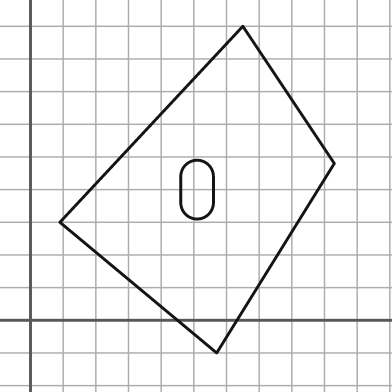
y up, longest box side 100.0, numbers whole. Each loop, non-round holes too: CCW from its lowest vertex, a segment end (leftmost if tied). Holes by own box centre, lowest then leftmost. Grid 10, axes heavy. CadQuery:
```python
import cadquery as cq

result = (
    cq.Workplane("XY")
    .moveTo(57.0, -10.0)
    .lineTo(93.0, 48.0)
    .lineTo(65.0, 90.0)
    .lineTo(9.0, 30.0)
    .close()
    .moveTo(46.0, 36.0)
    .threePointArc((51.0, 31.0), (56.0, 36.0))
    .lineTo(56.0, 44.0)
    .threePointArc((51.0, 49.0), (46.0, 44.0))
    .close()
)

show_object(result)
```